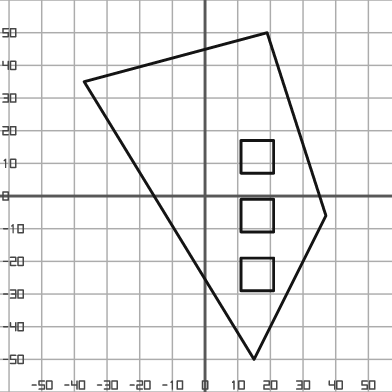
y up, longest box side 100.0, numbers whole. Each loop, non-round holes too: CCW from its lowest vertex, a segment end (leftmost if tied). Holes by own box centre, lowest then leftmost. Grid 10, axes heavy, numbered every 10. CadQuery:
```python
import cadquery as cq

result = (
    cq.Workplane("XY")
    .moveTo(15.0, -50.0)
    .lineTo(37.0, -6.0)
    .lineTo(19.0, 50.0)
    .lineTo(-37.0, 35.0)
    .close()
    .moveTo(11.0, -29.0)
    .lineTo(21.0, -29.0)
    .lineTo(21.0, -19.0)
    .lineTo(11.0, -19.0)
    .close()
    .moveTo(11.0, -11.0)
    .lineTo(21.0, -11.0)
    .lineTo(21.0, -1.0)
    .lineTo(11.0, -1.0)
    .close()
    .moveTo(11.0, 7.0)
    .lineTo(21.0, 7.0)
    .lineTo(21.0, 17.0)
    .lineTo(11.0, 17.0)
    .close()
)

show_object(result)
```